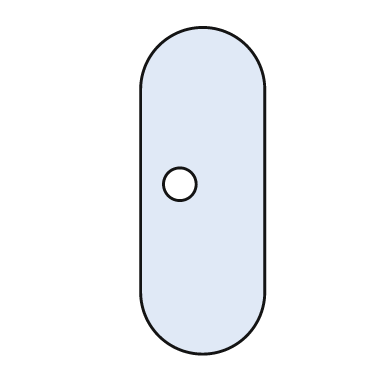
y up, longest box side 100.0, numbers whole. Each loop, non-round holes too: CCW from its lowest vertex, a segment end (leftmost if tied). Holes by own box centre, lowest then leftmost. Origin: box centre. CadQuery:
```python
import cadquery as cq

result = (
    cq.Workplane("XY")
    .moveTo(-19.0, -31.0)
    .threePointArc((0.0, -50.0), (19.0, -31.0))
    .lineTo(19.0, 31.0)
    .threePointArc((0.0, 50.0), (-19.0, 31.0))
    .close()
    .moveTo(-7.0, 2.0)
    .circle(5.0)
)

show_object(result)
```